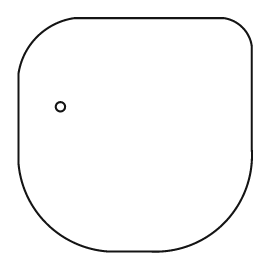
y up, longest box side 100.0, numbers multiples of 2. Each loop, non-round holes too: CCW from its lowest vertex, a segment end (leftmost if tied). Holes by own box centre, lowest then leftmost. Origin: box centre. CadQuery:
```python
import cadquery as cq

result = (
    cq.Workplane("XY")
    .moveTo(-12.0, -50.0)
    .lineTo(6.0, -50.0)
    .threePointArc((38.0, -38.0), (50.0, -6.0))
    .lineTo(50.0, 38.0)
    .threePointArc((46.0, 46.0), (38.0, 50.0))
    .lineTo(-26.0, 50.0)
    .threePointArc((-42.0, 42.0), (-50.0, 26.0))
    .lineTo(-50.0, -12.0)
    .threePointArc((-38.0, -38.0), (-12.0, -50.0))
    .close()
    .moveTo(-32.0, 12.0)
    .circle(2.0)
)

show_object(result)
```